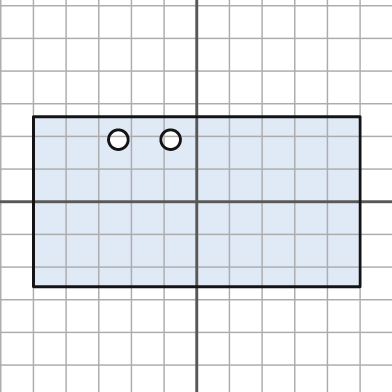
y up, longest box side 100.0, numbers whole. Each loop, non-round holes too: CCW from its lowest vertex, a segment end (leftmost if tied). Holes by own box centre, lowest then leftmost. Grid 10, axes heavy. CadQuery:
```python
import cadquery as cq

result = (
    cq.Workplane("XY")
    .moveTo(-50.0, -26.0)
    .lineTo(50.0, -26.0)
    .lineTo(50.0, 26.0)
    .lineTo(-50.0, 26.0)
    .close()
    .moveTo(-24.0, 19.0)
    .circle(3.0)
    .moveTo(-8.0, 19.0)
    .circle(3.0)
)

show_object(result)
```